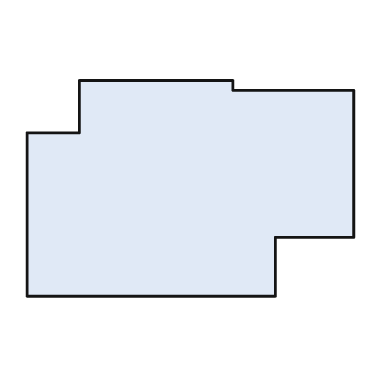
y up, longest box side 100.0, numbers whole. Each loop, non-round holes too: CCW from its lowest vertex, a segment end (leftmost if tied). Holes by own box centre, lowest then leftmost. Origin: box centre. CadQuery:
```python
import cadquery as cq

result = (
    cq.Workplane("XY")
    .moveTo(-50.0, -33.0)
    .lineTo(26.0, -33.0)
    .lineTo(26.0, -15.0)
    .lineTo(50.0, -15.0)
    .lineTo(50.0, 30.0)
    .lineTo(13.0, 30.0)
    .lineTo(13.0, 33.0)
    .lineTo(-34.0, 33.0)
    .lineTo(-34.0, 17.0)
    .lineTo(-50.0, 17.0)
    .close()
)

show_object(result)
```